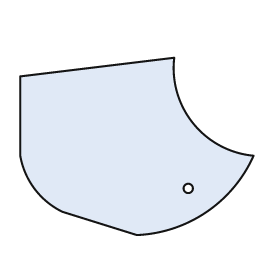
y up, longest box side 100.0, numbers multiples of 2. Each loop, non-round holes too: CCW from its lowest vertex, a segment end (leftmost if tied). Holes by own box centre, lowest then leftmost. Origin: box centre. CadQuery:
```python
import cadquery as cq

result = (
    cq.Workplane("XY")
    .moveTo(0.0, -38.0)
    .threePointArc((30.0, -28.0), (50.0, -4.0))
    .threePointArc((24.0, 10.0), (16.0, 38.0))
    .lineTo(-50.0, 30.0)
    .lineTo(-50.0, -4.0)
    .threePointArc((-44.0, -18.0), (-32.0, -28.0))
    .close()
    .moveTo(22.0, -18.0)
    .circle(2.0)
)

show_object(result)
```